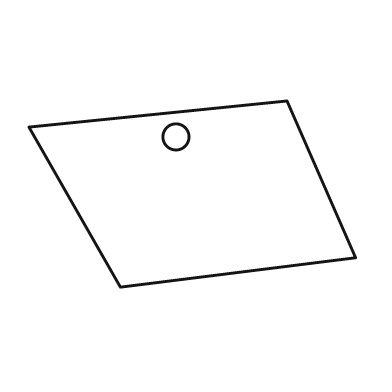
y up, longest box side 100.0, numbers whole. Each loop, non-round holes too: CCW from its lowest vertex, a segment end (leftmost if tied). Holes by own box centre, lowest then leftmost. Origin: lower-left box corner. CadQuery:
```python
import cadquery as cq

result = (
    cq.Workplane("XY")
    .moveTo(28.0, 0.0)
    .lineTo(100.0, 9.0)
    .lineTo(79.0, 57.0)
    .lineTo(0.0, 49.0)
    .close()
    .moveTo(45.0, 46.0)
    .circle(4.0)
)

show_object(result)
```